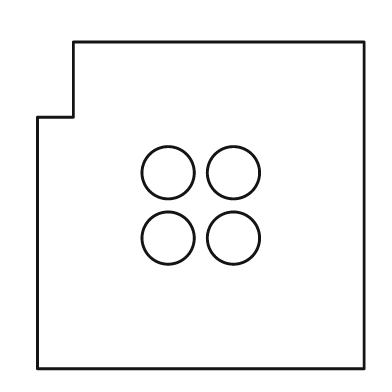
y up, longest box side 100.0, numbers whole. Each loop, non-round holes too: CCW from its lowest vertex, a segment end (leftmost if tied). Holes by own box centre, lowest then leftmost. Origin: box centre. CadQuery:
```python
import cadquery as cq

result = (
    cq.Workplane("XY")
    .moveTo(-50.0, -50.0)
    .lineTo(50.0, -50.0)
    .lineTo(50.0, 50.0)
    .lineTo(-39.0, 50.0)
    .lineTo(-39.0, 27.0)
    .lineTo(-50.0, 27.0)
    .close()
    .moveTo(-10.0, -10.0)
    .circle(8.0)
    .moveTo(10.0, -10.0)
    .circle(8.0)
    .moveTo(-10.0, 10.0)
    .circle(8.0)
    .moveTo(10.0, 10.0)
    .circle(8.0)
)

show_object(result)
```